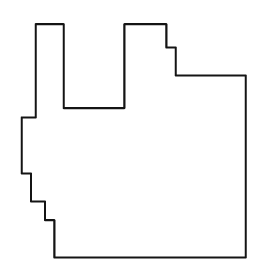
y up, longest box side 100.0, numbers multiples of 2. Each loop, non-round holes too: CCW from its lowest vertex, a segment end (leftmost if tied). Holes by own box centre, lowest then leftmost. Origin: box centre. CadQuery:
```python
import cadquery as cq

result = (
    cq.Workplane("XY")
    .moveTo(-34.0, -50.0)
    .lineTo(48.0, -50.0)
    .lineTo(48.0, 28.0)
    .lineTo(18.0, 28.0)
    .lineTo(18.0, 40.0)
    .lineTo(14.0, 40.0)
    .lineTo(14.0, 50.0)
    .lineTo(-4.0, 50.0)
    .lineTo(-4.0, 14.0)
    .lineTo(-30.0, 14.0)
    .lineTo(-30.0, 50.0)
    .lineTo(-42.0, 50.0)
    .lineTo(-42.0, 10.0)
    .lineTo(-48.0, 10.0)
    .lineTo(-48.0, -14.0)
    .lineTo(-44.0, -14.0)
    .lineTo(-44.0, -26.0)
    .lineTo(-38.0, -26.0)
    .lineTo(-38.0, -34.0)
    .lineTo(-34.0, -34.0)
    .close()
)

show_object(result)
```